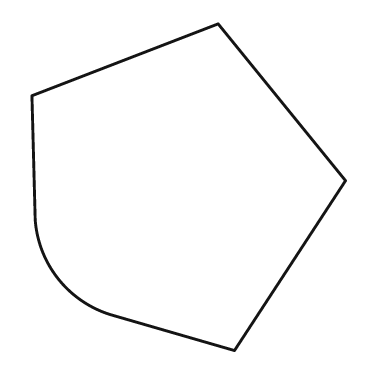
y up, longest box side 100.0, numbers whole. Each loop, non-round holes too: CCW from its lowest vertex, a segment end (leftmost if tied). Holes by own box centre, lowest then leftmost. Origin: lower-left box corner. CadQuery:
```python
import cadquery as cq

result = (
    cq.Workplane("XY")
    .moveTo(62.0, 0.0)
    .lineTo(96.0, 52.0)
    .lineTo(57.0, 100.0)
    .lineTo(0.0, 78.0)
    .lineTo(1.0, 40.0)
    .threePointArc((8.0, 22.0), (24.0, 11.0))
    .close()
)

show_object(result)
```